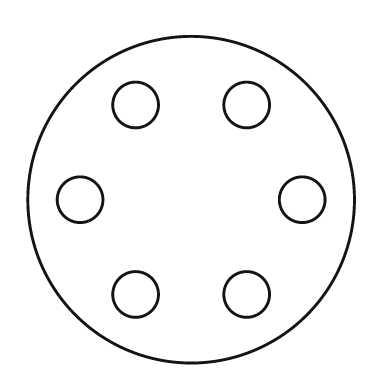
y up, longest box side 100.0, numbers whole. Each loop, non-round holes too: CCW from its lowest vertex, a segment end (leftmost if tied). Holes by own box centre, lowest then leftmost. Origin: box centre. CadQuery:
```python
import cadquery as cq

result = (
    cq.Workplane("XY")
    .moveTo(0.0, 0.0)
    .circle(50.0)
    .moveTo(-17.0, -29.0)
    .circle(7.0)
    .moveTo(17.0, -29.0)
    .circle(7.0)
    .moveTo(-34.0, 0.0)
    .circle(7.0)
    .moveTo(34.0, 0.0)
    .circle(7.0)
    .moveTo(-17.0, 29.0)
    .circle(7.0)
    .moveTo(17.0, 29.0)
    .circle(7.0)
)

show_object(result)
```